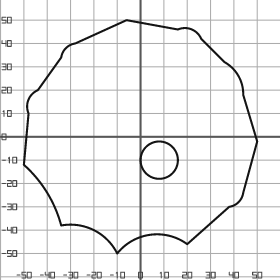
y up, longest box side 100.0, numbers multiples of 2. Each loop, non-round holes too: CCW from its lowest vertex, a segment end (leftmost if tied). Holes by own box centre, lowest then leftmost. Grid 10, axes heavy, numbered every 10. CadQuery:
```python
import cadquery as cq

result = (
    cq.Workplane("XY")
    .moveTo(-10.0, -50.0)
    .threePointArc((4.0, -42.0), (20.0, -46.0))
    .lineTo(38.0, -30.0)
    .threePointArc((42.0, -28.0), (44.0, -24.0))
    .lineTo(50.0, -2.0)
    .lineTo(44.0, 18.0)
    .threePointArc((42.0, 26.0), (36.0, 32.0))
    .lineTo(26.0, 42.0)
    .threePointArc((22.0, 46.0), (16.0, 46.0))
    .lineTo(-6.0, 50.0)
    .lineTo(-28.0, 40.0)
    .threePointArc((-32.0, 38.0), (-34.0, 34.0))
    .lineTo(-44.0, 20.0)
    .threePointArc((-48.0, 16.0), (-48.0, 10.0))
    .lineTo(-50.0, -12.0)
    .threePointArc((-40.0, -24.0), (-34.0, -38.0))
    .threePointArc((-20.0, -40.0), (-10.0, -50.0))
    .close()
    .moveTo(8.0, -10.0)
    .circle(8.0)
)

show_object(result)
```